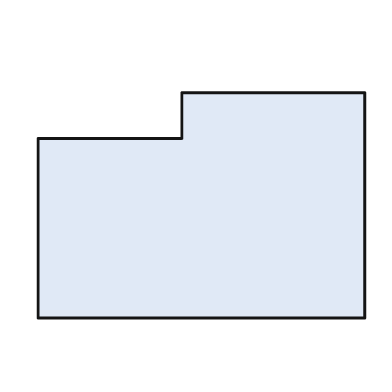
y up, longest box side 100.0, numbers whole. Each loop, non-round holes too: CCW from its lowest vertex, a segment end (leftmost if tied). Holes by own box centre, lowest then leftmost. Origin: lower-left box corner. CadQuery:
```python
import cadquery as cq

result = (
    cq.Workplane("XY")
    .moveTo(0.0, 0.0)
    .lineTo(100.0, 0.0)
    .lineTo(100.0, 69.0)
    .lineTo(44.0, 69.0)
    .lineTo(44.0, 55.0)
    .lineTo(0.0, 55.0)
    .close()
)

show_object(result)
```